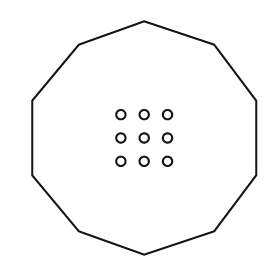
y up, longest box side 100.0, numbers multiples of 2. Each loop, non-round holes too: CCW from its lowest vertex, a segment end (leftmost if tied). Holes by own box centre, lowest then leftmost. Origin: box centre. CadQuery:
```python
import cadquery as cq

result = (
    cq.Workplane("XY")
    .moveTo(0.0, -50.0)
    .lineTo(30.0, -40.0)
    .lineTo(48.0, -16.0)
    .lineTo(48.0, 16.0)
    .lineTo(30.0, 40.0)
    .lineTo(0.0, 50.0)
    .lineTo(-28.0, 40.0)
    .lineTo(-48.0, 16.0)
    .lineTo(-48.0, -16.0)
    .lineTo(-28.0, -40.0)
    .close()
    .moveTo(-10.0, -10.0)
    .circle(2.0)
    .moveTo(0.0, -10.0)
    .circle(2.0)
    .moveTo(10.0, -10.0)
    .circle(2.0)
    .moveTo(-10.0, 0.0)
    .circle(2.0)
    .moveTo(0.0, 0.0)
    .circle(2.0)
    .moveTo(10.0, 0.0)
    .circle(2.0)
    .moveTo(-10.0, 10.0)
    .circle(2.0)
    .moveTo(0.0, 10.0)
    .circle(2.0)
    .moveTo(10.0, 10.0)
    .circle(2.0)
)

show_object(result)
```